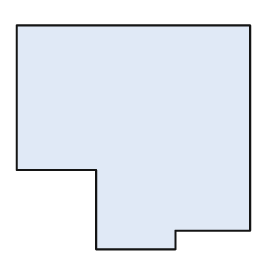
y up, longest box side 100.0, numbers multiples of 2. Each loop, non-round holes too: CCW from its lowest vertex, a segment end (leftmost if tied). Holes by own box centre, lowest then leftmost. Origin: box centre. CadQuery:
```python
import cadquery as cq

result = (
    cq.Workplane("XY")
    .moveTo(-16.0, -48.0)
    .lineTo(18.0, -48.0)
    .lineTo(18.0, -40.0)
    .lineTo(50.0, -40.0)
    .lineTo(50.0, 48.0)
    .lineTo(-50.0, 48.0)
    .lineTo(-50.0, -14.0)
    .lineTo(-16.0, -14.0)
    .close()
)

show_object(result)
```